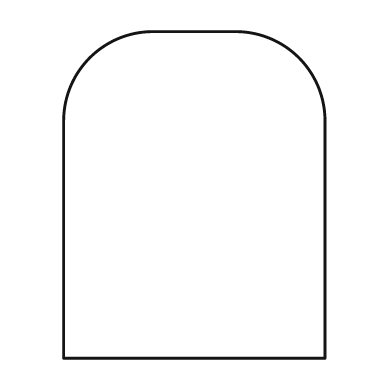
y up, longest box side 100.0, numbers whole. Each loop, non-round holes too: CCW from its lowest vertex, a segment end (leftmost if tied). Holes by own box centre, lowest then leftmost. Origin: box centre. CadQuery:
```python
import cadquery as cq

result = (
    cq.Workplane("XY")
    .moveTo(-40.0, -50.0)
    .lineTo(40.0, -50.0)
    .lineTo(40.0, 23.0)
    .threePointArc((32.0, 42.0), (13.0, 50.0))
    .lineTo(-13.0, 50.0)
    .threePointArc((-32.0, 42.0), (-40.0, 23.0))
    .close()
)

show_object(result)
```